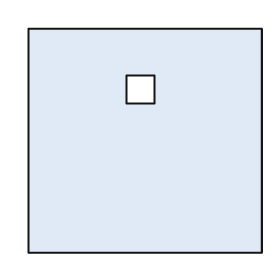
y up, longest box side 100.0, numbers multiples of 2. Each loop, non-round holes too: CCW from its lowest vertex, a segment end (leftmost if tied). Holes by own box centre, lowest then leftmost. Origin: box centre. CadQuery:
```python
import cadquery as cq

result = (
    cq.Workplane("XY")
    .moveTo(-50.0, -48.0)
    .lineTo(50.0, -48.0)
    .lineTo(50.0, 48.0)
    .lineTo(-50.0, 48.0)
    .close()
    .moveTo(-8.0, 16.0)
    .lineTo(4.0, 16.0)
    .lineTo(4.0, 28.0)
    .lineTo(-8.0, 28.0)
    .close()
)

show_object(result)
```